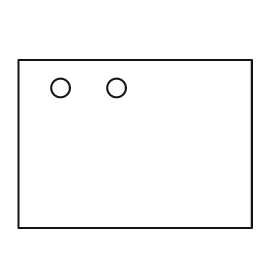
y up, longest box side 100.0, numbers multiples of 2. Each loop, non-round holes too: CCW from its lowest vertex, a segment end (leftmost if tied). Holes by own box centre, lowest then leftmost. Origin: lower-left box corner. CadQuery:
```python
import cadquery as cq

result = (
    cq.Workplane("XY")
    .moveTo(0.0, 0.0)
    .lineTo(100.0, 0.0)
    .lineTo(100.0, 72.0)
    .lineTo(0.0, 72.0)
    .close()
    .moveTo(18.0, 60.0)
    .circle(4.0)
    .moveTo(42.0, 60.0)
    .circle(4.0)
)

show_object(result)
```